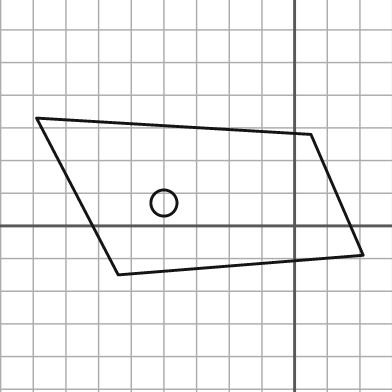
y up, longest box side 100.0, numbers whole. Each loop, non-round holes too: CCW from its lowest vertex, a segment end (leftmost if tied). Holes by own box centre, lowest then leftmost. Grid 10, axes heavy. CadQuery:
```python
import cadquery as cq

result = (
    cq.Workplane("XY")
    .moveTo(-54.0, -15.0)
    .lineTo(21.0, -9.0)
    .lineTo(5.0, 28.0)
    .lineTo(-79.0, 33.0)
    .close()
    .moveTo(-40.0, 7.0)
    .circle(4.0)
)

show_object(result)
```